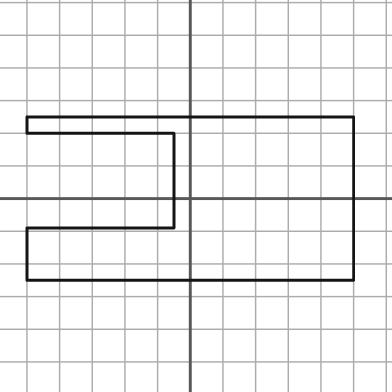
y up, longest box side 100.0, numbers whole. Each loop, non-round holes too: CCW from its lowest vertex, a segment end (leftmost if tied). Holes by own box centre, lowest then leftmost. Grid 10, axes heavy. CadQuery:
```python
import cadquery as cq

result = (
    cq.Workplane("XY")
    .moveTo(-50.0, -25.0)
    .lineTo(50.0, -25.0)
    .lineTo(50.0, 25.0)
    .lineTo(-50.0, 25.0)
    .lineTo(-50.0, 20.0)
    .lineTo(-5.0, 20.0)
    .lineTo(-5.0, -9.0)
    .lineTo(-50.0, -9.0)
    .close()
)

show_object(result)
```